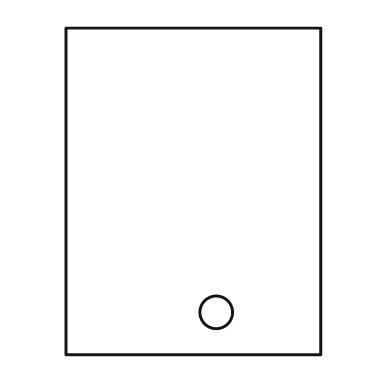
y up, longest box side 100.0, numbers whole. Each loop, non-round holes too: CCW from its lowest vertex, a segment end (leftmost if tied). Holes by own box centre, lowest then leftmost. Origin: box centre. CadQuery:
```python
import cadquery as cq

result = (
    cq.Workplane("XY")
    .moveTo(-39.0, -50.0)
    .lineTo(39.0, -50.0)
    .lineTo(39.0, 50.0)
    .lineTo(-39.0, 50.0)
    .close()
    .moveTo(7.0, -37.0)
    .circle(5.0)
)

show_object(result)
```